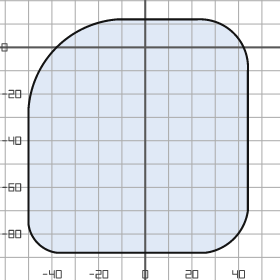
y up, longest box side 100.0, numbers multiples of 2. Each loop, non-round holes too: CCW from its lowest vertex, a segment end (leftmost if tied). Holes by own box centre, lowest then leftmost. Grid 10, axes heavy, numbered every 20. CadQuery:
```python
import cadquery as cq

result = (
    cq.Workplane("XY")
    .moveTo(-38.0, -88.0)
    .lineTo(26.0, -88.0)
    .threePointArc((38.0, -82.0), (44.0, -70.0))
    .lineTo(44.0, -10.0)
    .threePointArc((38.0, 6.0), (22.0, 12.0))
    .lineTo(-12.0, 12.0)
    .threePointArc((-38.0, 0.0), (-50.0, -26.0))
    .lineTo(-50.0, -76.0)
    .threePointArc((-46.0, -84.0), (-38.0, -88.0))
    .close()
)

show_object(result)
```